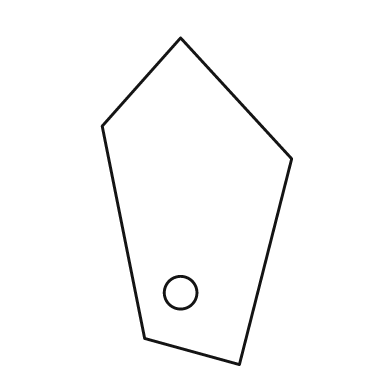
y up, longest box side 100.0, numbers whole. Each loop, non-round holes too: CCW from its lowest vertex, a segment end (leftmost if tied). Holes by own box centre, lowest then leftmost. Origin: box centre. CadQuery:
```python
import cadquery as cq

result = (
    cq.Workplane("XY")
    .moveTo(13.0, -50.0)
    .lineTo(29.0, 13.0)
    .lineTo(-5.0, 50.0)
    .lineTo(-29.0, 23.0)
    .lineTo(-16.0, -42.0)
    .close()
    .moveTo(-5.0, -28.0)
    .circle(5.0)
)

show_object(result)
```